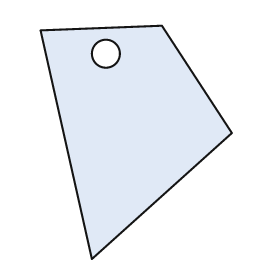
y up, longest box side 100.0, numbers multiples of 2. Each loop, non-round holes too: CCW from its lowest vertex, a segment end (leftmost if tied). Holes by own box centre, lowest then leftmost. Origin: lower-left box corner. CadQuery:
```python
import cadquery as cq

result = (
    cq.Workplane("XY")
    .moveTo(22.0, 0.0)
    .lineTo(82.0, 54.0)
    .lineTo(52.0, 100.0)
    .lineTo(0.0, 98.0)
    .close()
    .moveTo(28.0, 88.0)
    .circle(6.0)
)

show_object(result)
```